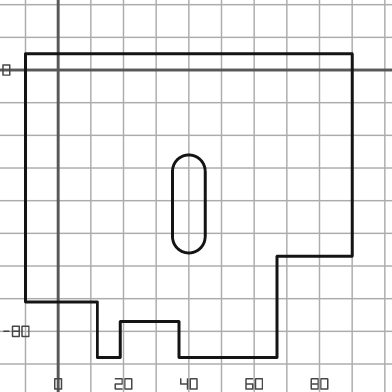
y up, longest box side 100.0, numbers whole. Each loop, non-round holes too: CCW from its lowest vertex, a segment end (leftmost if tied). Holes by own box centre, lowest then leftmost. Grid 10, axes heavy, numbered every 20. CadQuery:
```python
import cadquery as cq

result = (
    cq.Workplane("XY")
    .moveTo(12.0, -88.0)
    .lineTo(19.0, -88.0)
    .lineTo(19.0, -77.0)
    .lineTo(37.0, -77.0)
    .lineTo(37.0, -88.0)
    .lineTo(67.0, -88.0)
    .lineTo(67.0, -57.0)
    .lineTo(90.0, -57.0)
    .lineTo(90.0, 5.0)
    .lineTo(-10.0, 5.0)
    .lineTo(-10.0, -71.0)
    .lineTo(12.0, -71.0)
    .close()
    .moveTo(35.0, -51.0)
    .threePointArc((40.0, -56.0), (45.0, -51.0))
    .lineTo(45.0, -31.0)
    .threePointArc((40.0, -26.0), (35.0, -31.0))
    .close()
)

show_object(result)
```